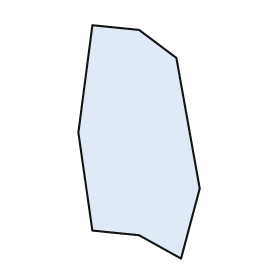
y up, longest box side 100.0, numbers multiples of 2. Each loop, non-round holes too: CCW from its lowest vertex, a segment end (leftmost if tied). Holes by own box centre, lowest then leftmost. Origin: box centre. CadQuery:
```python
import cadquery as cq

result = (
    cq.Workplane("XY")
    .moveTo(18.0, -50.0)
    .lineTo(26.0, -20.0)
    .lineTo(16.0, 36.0)
    .lineTo(0.0, 48.0)
    .lineTo(-20.0, 50.0)
    .lineTo(-26.0, 4.0)
    .lineTo(-20.0, -38.0)
    .lineTo(0.0, -40.0)
    .close()
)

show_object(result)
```